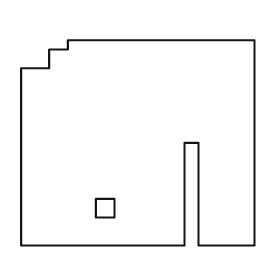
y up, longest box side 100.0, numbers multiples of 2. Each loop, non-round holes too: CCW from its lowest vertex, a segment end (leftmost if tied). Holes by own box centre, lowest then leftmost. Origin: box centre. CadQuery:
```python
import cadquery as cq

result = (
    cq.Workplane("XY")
    .moveTo(-50.0, -44.0)
    .lineTo(20.0, -44.0)
    .lineTo(20.0, 0.0)
    .lineTo(26.0, 0.0)
    .lineTo(26.0, -44.0)
    .lineTo(50.0, -44.0)
    .lineTo(50.0, 44.0)
    .lineTo(-30.0, 44.0)
    .lineTo(-30.0, 40.0)
    .lineTo(-38.0, 40.0)
    .lineTo(-38.0, 32.0)
    .lineTo(-50.0, 32.0)
    .close()
    .moveTo(-18.0, -32.0)
    .lineTo(-10.0, -32.0)
    .lineTo(-10.0, -24.0)
    .lineTo(-18.0, -24.0)
    .close()
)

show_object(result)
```